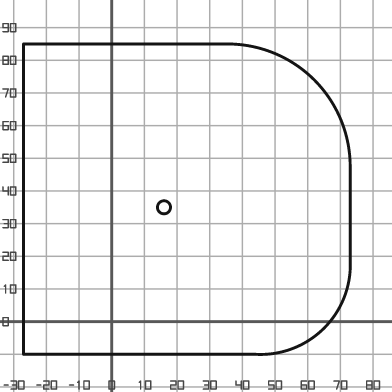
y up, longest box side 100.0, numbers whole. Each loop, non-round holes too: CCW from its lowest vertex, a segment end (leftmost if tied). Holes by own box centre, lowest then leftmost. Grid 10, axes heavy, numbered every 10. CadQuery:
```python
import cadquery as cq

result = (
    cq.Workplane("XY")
    .moveTo(-27.0, -10.0)
    .lineTo(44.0, -10.0)
    .threePointArc((65.0, -2.0), (73.0, 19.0))
    .lineTo(73.0, 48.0)
    .threePointArc((62.0, 74.0), (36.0, 85.0))
    .lineTo(-27.0, 85.0)
    .close()
    .moveTo(16.0, 35.0)
    .circle(2.0)
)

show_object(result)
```